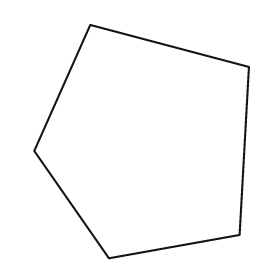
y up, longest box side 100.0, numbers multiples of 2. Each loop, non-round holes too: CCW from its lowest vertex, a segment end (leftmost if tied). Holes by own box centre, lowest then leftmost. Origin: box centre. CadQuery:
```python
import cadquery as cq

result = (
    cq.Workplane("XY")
    .moveTo(-14.0, -50.0)
    .lineTo(42.0, -40.0)
    .lineTo(46.0, 32.0)
    .lineTo(-22.0, 50.0)
    .lineTo(-46.0, -4.0)
    .close()
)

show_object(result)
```